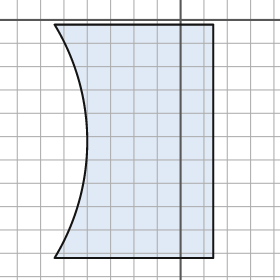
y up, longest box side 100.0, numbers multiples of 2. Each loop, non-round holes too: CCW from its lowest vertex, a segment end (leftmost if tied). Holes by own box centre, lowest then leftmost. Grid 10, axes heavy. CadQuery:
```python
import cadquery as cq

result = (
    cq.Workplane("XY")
    .moveTo(-54.0, -102.0)
    .lineTo(14.0, -102.0)
    .lineTo(14.0, -2.0)
    .lineTo(-54.0, -2.0)
    .threePointArc((-40.0, -52.0), (-54.0, -102.0))
    .close()
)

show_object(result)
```